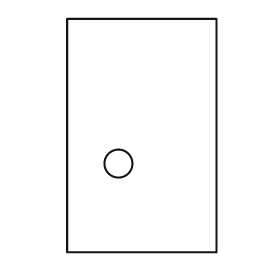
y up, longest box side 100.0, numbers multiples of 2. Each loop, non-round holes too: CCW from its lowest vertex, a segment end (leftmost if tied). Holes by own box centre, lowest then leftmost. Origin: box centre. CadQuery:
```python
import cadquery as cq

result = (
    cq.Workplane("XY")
    .moveTo(-32.0, -50.0)
    .lineTo(32.0, -50.0)
    .lineTo(32.0, 50.0)
    .lineTo(-32.0, 50.0)
    .close()
    .moveTo(-10.0, -12.0)
    .circle(6.0)
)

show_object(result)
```